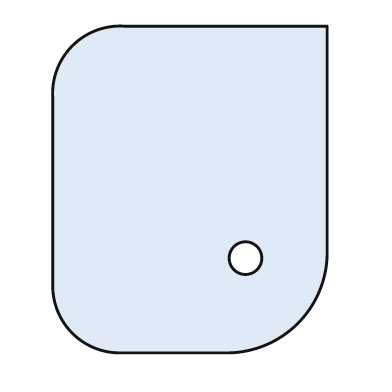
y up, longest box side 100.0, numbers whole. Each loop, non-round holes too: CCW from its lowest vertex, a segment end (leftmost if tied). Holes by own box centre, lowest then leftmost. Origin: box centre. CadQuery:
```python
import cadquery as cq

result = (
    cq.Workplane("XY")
    .moveTo(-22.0, -50.0)
    .lineTo(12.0, -50.0)
    .threePointArc((33.0, -41.0), (42.0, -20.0))
    .lineTo(42.0, 50.0)
    .lineTo(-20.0, 50.0)
    .threePointArc((-36.0, 44.0), (-42.0, 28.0))
    .lineTo(-42.0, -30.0)
    .threePointArc((-36.0, -44.0), (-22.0, -50.0))
    .close()
    .moveTo(17.0, -21.0)
    .circle(5.0)
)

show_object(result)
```